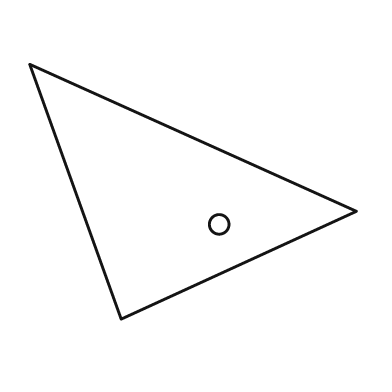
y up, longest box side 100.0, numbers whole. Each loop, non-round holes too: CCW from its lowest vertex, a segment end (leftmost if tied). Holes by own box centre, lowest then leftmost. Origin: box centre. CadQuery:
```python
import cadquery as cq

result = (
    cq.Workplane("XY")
    .moveTo(-22.0, -39.0)
    .lineTo(50.0, -6.0)
    .lineTo(-50.0, 39.0)
    .close()
    .moveTo(8.0, -10.0)
    .circle(3.0)
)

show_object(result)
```